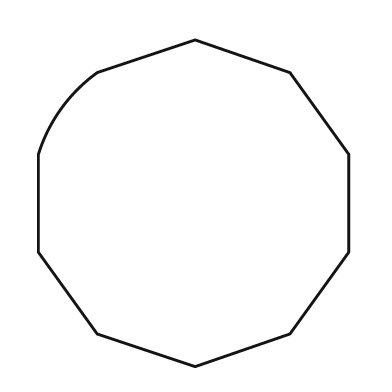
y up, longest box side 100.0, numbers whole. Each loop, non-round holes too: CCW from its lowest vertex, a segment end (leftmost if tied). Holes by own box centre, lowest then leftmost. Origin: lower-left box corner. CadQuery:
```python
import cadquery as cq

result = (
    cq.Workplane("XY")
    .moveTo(48.0, 0.0)
    .lineTo(77.0, 10.0)
    .lineTo(95.0, 35.0)
    .lineTo(95.0, 65.0)
    .lineTo(77.0, 90.0)
    .lineTo(48.0, 100.0)
    .lineTo(18.0, 90.0)
    .threePointArc((7.0, 79.0), (0.0, 65.0))
    .lineTo(0.0, 35.0)
    .lineTo(18.0, 10.0)
    .close()
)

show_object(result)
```